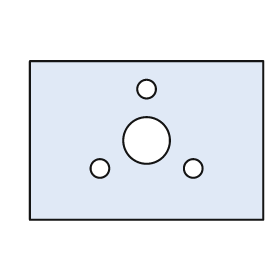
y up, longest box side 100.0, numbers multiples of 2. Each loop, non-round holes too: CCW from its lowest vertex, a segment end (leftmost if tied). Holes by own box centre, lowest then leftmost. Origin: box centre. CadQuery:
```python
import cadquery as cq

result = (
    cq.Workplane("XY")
    .moveTo(-50.0, -34.0)
    .lineTo(50.0, -34.0)
    .lineTo(50.0, 34.0)
    .lineTo(-50.0, 34.0)
    .close()
    .moveTo(-20.0, -12.0)
    .circle(4.0)
    .moveTo(20.0, -12.0)
    .circle(4.0)
    .moveTo(0.0, 0.0)
    .circle(10.0)
    .moveTo(0.0, 22.0)
    .circle(4.0)
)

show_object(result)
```